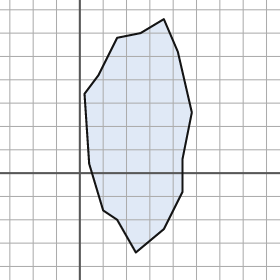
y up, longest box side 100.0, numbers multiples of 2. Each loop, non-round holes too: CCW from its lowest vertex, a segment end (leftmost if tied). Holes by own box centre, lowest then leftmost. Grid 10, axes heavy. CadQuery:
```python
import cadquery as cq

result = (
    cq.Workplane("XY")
    .moveTo(24.0, -34.0)
    .lineTo(36.0, -24.0)
    .lineTo(44.0, -8.0)
    .lineTo(44.0, 6.0)
    .lineTo(48.0, 26.0)
    .lineTo(42.0, 52.0)
    .lineTo(36.0, 66.0)
    .lineTo(26.0, 60.0)
    .lineTo(16.0, 58.0)
    .lineTo(8.0, 42.0)
    .lineTo(2.0, 34.0)
    .lineTo(4.0, 4.0)
    .lineTo(10.0, -16.0)
    .lineTo(16.0, -20.0)
    .close()
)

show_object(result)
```